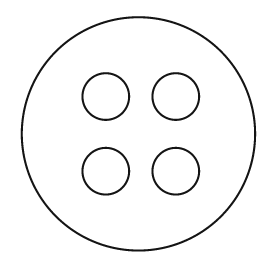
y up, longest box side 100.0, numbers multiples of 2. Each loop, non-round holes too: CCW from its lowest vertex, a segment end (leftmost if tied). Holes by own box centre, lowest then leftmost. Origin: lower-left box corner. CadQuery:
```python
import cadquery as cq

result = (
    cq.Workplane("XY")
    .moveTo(50.0, 50.0)
    .circle(50.0)
    .moveTo(36.0, 34.0)
    .circle(10.0)
    .moveTo(66.0, 34.0)
    .circle(10.0)
    .moveTo(36.0, 66.0)
    .circle(10.0)
    .moveTo(66.0, 66.0)
    .circle(10.0)
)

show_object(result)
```